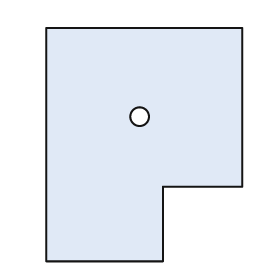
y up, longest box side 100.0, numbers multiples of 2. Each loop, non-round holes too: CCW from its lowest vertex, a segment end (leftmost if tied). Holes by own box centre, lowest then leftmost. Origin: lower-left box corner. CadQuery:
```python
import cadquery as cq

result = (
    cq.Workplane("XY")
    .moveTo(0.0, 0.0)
    .lineTo(50.0, 0.0)
    .lineTo(50.0, 32.0)
    .lineTo(84.0, 32.0)
    .lineTo(84.0, 100.0)
    .lineTo(0.0, 100.0)
    .close()
    .moveTo(40.0, 62.0)
    .circle(4.0)
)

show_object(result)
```